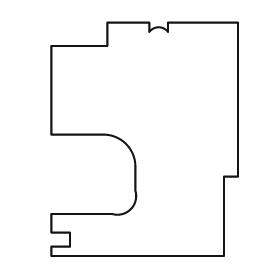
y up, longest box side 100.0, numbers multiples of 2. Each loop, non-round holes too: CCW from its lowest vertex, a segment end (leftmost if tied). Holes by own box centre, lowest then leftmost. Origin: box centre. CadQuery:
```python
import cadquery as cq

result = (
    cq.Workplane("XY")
    .moveTo(-40.0, -50.0)
    .lineTo(34.0, -50.0)
    .lineTo(34.0, -16.0)
    .lineTo(40.0, -16.0)
    .lineTo(40.0, 50.0)
    .lineTo(10.0, 50.0)
    .lineTo(10.0, 46.0)
    .threePointArc((6.0, 48.0), (2.0, 46.0))
    .lineTo(2.0, 50.0)
    .lineTo(-16.0, 50.0)
    .lineTo(-16.0, 40.0)
    .lineTo(-40.0, 40.0)
    .lineTo(-40.0, 2.0)
    .lineTo(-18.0, 2.0)
    .threePointArc((-8.0, -2.0), (-4.0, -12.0))
    .lineTo(-4.0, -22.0)
    .threePointArc((-6.0, -30.0), (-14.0, -32.0))
    .lineTo(-40.0, -32.0)
    .lineTo(-40.0, -40.0)
    .lineTo(-32.0, -40.0)
    .lineTo(-32.0, -46.0)
    .lineTo(-40.0, -46.0)
    .close()
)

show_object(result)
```